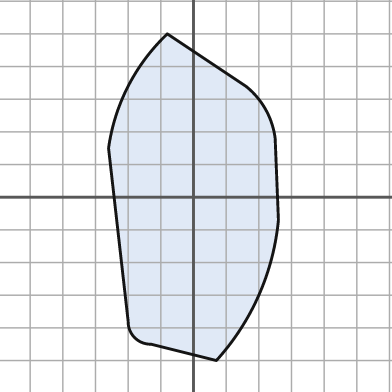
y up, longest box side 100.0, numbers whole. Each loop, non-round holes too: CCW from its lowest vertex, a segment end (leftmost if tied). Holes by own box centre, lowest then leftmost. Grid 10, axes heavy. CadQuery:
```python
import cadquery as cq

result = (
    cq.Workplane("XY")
    .moveTo(7.0, -50.0)
    .threePointArc((20.0, -30.0), (26.0, -7.0))
    .lineTo(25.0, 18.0)
    .threePointArc((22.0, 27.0), (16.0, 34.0))
    .lineTo(-8.0, 50.0)
    .threePointArc((-20.0, 34.0), (-26.0, 15.0))
    .lineTo(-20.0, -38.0)
    .threePointArc((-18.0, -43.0), (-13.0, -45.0))
    .close()
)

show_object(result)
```